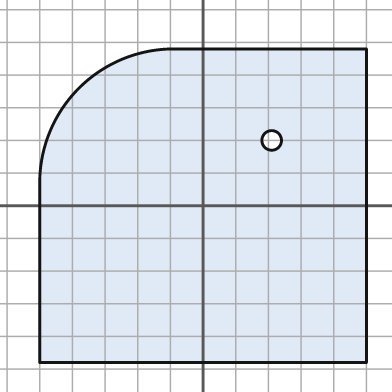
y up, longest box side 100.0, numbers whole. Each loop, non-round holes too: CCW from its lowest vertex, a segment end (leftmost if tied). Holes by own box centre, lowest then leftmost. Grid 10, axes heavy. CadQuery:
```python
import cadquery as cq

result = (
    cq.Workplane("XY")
    .moveTo(-50.0, -48.0)
    .lineTo(50.0, -48.0)
    .lineTo(50.0, 48.0)
    .lineTo(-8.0, 48.0)
    .threePointArc((-38.0, 36.0), (-50.0, 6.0))
    .close()
    .moveTo(21.0, 20.0)
    .circle(3.0)
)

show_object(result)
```